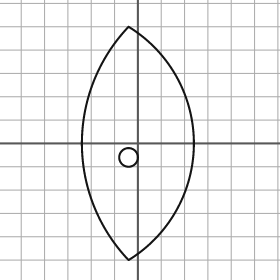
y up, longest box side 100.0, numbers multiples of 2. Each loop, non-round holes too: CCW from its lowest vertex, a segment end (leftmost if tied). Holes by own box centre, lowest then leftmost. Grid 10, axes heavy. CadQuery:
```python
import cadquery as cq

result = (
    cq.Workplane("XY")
    .moveTo(-4.0, -50.0)
    .threePointArc((24.0, 0.0), (-4.0, 50.0))
    .threePointArc((-24.0, 0.0), (-4.0, -50.0))
    .close()
    .moveTo(-4.0, -6.0)
    .circle(4.0)
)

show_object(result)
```